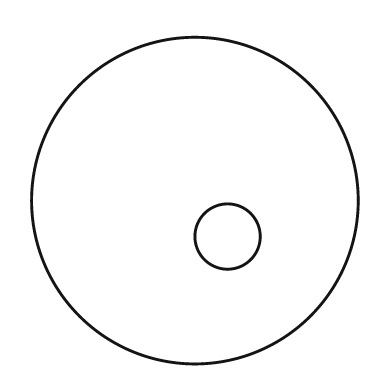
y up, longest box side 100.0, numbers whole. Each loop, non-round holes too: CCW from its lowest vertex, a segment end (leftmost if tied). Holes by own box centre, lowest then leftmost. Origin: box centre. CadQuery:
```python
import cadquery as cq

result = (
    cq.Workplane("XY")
    .moveTo(0.0, 0.0)
    .circle(50.0)
    .moveTo(10.0, -11.0)
    .circle(10.0)
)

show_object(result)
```